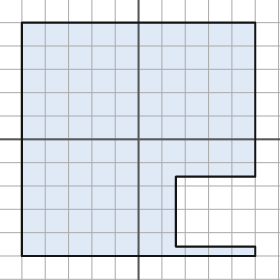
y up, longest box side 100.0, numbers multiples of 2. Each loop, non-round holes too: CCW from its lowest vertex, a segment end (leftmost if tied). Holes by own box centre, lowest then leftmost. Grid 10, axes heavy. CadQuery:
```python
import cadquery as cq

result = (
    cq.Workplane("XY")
    .moveTo(-50.0, -50.0)
    .lineTo(50.0, -50.0)
    .lineTo(50.0, -46.0)
    .lineTo(16.0, -46.0)
    .lineTo(16.0, -16.0)
    .lineTo(50.0, -16.0)
    .lineTo(50.0, 50.0)
    .lineTo(-50.0, 50.0)
    .close()
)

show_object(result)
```